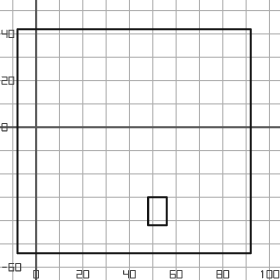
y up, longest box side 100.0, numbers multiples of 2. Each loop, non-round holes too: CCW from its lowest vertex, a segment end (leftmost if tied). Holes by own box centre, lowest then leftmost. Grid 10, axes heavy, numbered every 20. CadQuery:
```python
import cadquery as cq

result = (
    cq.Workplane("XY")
    .moveTo(-8.0, -54.0)
    .lineTo(92.0, -54.0)
    .lineTo(92.0, 42.0)
    .lineTo(-8.0, 42.0)
    .close()
    .moveTo(48.0, -42.0)
    .lineTo(56.0, -42.0)
    .lineTo(56.0, -30.0)
    .lineTo(48.0, -30.0)
    .close()
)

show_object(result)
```